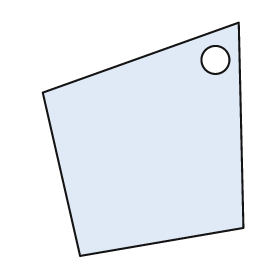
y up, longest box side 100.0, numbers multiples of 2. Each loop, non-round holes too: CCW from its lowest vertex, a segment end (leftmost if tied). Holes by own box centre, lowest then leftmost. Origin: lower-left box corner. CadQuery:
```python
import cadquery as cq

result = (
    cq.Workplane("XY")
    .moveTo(16.0, 0.0)
    .lineTo(86.0, 12.0)
    .lineTo(84.0, 100.0)
    .lineTo(0.0, 70.0)
    .close()
    .moveTo(74.0, 84.0)
    .circle(6.0)
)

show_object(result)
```